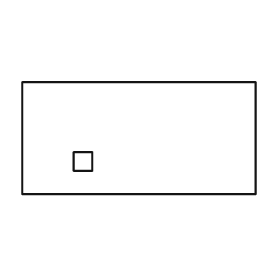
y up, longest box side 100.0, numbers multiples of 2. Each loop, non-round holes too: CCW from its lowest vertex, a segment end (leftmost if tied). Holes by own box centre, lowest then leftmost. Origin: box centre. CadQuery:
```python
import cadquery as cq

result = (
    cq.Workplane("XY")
    .moveTo(-50.0, -24.0)
    .lineTo(50.0, -24.0)
    .lineTo(50.0, 24.0)
    .lineTo(-50.0, 24.0)
    .close()
    .moveTo(-28.0, -14.0)
    .lineTo(-20.0, -14.0)
    .lineTo(-20.0, -6.0)
    .lineTo(-28.0, -6.0)
    .close()
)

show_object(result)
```